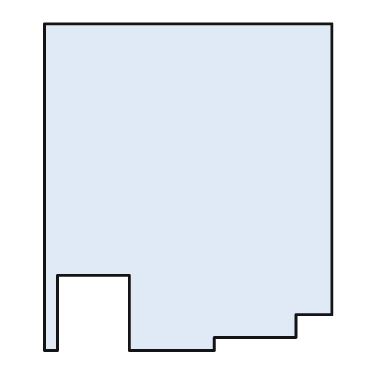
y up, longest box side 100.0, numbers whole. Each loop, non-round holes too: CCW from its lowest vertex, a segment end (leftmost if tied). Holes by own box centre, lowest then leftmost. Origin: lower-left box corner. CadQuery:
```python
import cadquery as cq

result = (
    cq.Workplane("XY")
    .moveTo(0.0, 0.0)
    .lineTo(4.0, 0.0)
    .lineTo(4.0, 23.0)
    .lineTo(26.0, 23.0)
    .lineTo(26.0, 0.0)
    .lineTo(52.0, 0.0)
    .lineTo(52.0, 4.0)
    .lineTo(77.0, 4.0)
    .lineTo(77.0, 11.0)
    .lineTo(88.0, 11.0)
    .lineTo(88.0, 100.0)
    .lineTo(0.0, 100.0)
    .close()
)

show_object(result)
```